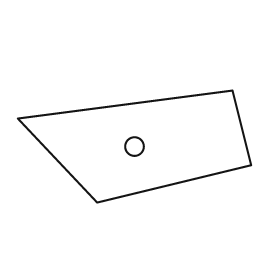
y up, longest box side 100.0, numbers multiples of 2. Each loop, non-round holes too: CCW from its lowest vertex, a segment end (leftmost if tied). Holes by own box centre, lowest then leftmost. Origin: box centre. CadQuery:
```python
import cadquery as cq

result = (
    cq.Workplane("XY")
    .moveTo(-16.0, -24.0)
    .lineTo(50.0, -8.0)
    .lineTo(42.0, 24.0)
    .lineTo(-50.0, 12.0)
    .close()
    .moveTo(0.0, 0.0)
    .circle(4.0)
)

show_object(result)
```